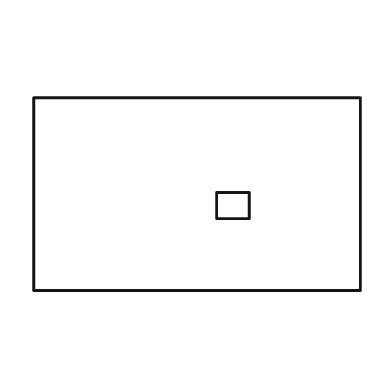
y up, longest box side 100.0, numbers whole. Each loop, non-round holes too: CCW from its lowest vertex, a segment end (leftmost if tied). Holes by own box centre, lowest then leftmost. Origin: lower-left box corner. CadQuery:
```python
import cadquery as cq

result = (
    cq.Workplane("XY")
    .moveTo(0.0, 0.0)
    .lineTo(100.0, 0.0)
    .lineTo(100.0, 59.0)
    .lineTo(0.0, 59.0)
    .close()
    .moveTo(56.0, 22.0)
    .lineTo(66.0, 22.0)
    .lineTo(66.0, 30.0)
    .lineTo(56.0, 30.0)
    .close()
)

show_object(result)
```